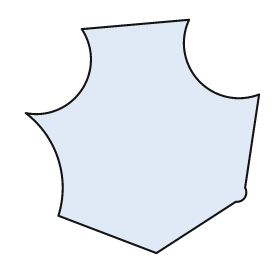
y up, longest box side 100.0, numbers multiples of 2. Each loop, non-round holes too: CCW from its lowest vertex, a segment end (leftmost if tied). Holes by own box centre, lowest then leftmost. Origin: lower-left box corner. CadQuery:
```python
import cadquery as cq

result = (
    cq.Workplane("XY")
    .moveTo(56.0, 0.0)
    .lineTo(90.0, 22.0)
    .threePointArc((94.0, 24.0), (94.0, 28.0))
    .lineTo(100.0, 68.0)
    .threePointArc((74.0, 74.0), (70.0, 100.0))
    .lineTo(24.0, 96.0)
    .threePointArc((24.0, 70.0), (0.0, 60.0))
    .threePointArc((14.0, 40.0), (14.0, 16.0))
    .close()
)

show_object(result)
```